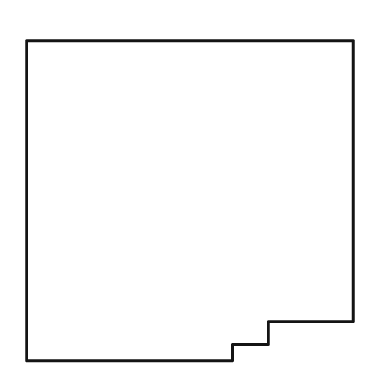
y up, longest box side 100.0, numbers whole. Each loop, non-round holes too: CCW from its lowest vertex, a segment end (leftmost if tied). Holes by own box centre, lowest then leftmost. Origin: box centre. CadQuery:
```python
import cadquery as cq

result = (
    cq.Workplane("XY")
    .moveTo(-50.0, -49.0)
    .lineTo(13.0, -49.0)
    .lineTo(13.0, -44.0)
    .lineTo(24.0, -44.0)
    .lineTo(24.0, -37.0)
    .lineTo(50.0, -37.0)
    .lineTo(50.0, 49.0)
    .lineTo(-50.0, 49.0)
    .close()
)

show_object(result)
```